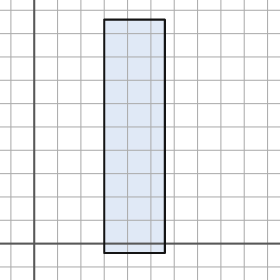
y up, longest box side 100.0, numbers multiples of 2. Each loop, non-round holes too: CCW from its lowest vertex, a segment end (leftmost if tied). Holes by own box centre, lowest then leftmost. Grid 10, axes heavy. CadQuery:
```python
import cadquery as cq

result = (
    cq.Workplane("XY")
    .moveTo(30.0, -4.0)
    .lineTo(56.0, -4.0)
    .lineTo(56.0, 96.0)
    .lineTo(30.0, 96.0)
    .close()
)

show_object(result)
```